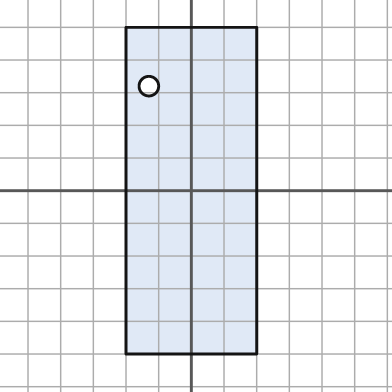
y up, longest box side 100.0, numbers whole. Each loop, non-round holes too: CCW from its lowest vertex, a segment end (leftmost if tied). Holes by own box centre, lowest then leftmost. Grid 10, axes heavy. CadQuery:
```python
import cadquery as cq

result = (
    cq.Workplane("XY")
    .moveTo(-20.0, -50.0)
    .lineTo(20.0, -50.0)
    .lineTo(20.0, 50.0)
    .lineTo(-20.0, 50.0)
    .close()
    .moveTo(-13.0, 32.0)
    .circle(3.0)
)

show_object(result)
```